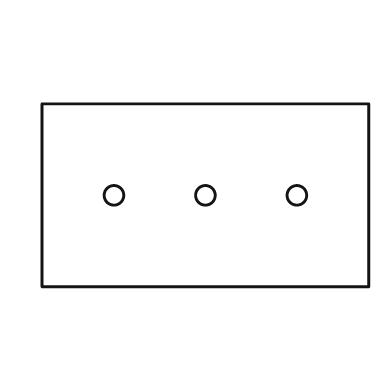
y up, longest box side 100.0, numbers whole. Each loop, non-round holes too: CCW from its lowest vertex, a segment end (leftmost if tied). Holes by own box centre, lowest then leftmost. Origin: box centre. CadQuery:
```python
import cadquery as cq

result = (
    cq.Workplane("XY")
    .moveTo(-50.0, -28.0)
    .lineTo(50.0, -28.0)
    .lineTo(50.0, 28.0)
    .lineTo(-50.0, 28.0)
    .close()
    .moveTo(-28.0, 0.0)
    .circle(3.0)
    .moveTo(0.0, 0.0)
    .circle(3.0)
    .moveTo(28.0, 0.0)
    .circle(3.0)
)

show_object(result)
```